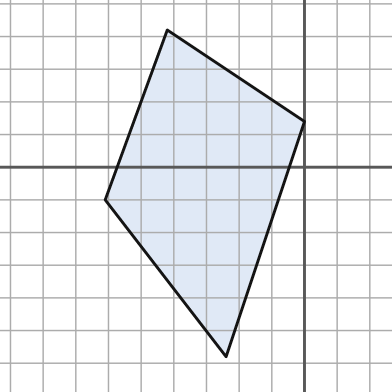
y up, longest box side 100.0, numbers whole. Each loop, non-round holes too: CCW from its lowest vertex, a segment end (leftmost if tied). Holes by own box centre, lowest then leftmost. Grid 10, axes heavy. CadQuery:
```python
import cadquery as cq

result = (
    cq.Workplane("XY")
    .moveTo(-24.0, -58.0)
    .lineTo(0.0, 14.0)
    .lineTo(-42.0, 42.0)
    .lineTo(-61.0, -10.0)
    .close()
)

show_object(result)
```